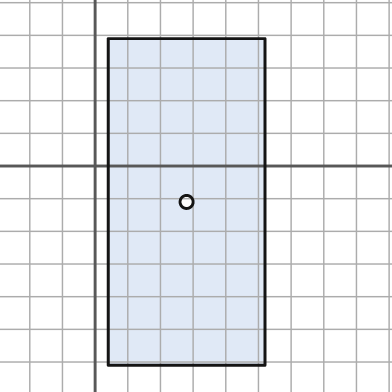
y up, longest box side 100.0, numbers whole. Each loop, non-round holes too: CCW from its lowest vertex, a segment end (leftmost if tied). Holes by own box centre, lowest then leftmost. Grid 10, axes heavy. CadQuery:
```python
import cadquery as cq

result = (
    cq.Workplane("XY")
    .moveTo(4.0, -61.0)
    .lineTo(52.0, -61.0)
    .lineTo(52.0, 39.0)
    .lineTo(4.0, 39.0)
    .close()
    .moveTo(28.0, -11.0)
    .circle(2.0)
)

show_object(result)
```